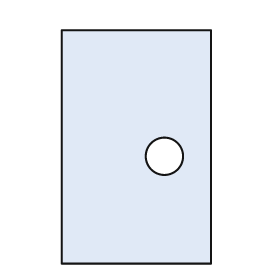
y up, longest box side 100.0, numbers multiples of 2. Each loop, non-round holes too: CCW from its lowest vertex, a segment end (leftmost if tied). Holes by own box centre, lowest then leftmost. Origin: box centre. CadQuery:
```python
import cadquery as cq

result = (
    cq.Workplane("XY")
    .moveTo(-32.0, -50.0)
    .lineTo(32.0, -50.0)
    .lineTo(32.0, 50.0)
    .lineTo(-32.0, 50.0)
    .close()
    .moveTo(12.0, -4.0)
    .circle(8.0)
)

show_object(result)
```